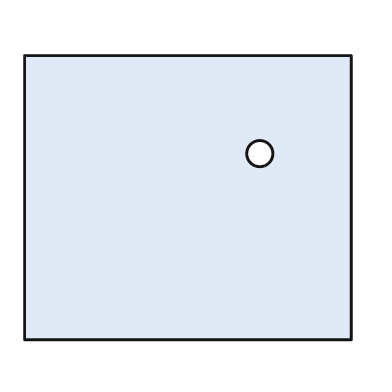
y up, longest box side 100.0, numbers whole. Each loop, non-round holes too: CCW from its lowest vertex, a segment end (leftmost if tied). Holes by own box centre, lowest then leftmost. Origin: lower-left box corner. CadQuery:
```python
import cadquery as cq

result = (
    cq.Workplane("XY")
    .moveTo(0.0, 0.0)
    .lineTo(100.0, 0.0)
    .lineTo(100.0, 87.0)
    .lineTo(0.0, 87.0)
    .close()
    .moveTo(72.0, 57.0)
    .circle(4.0)
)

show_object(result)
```